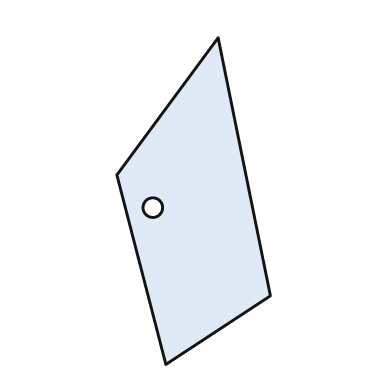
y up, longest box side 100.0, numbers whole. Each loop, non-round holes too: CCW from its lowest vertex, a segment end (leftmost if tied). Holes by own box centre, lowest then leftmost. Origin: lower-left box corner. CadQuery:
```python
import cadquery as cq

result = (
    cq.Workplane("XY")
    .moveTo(15.0, 0.0)
    .lineTo(47.0, 21.0)
    .lineTo(31.0, 100.0)
    .lineTo(0.0, 58.0)
    .close()
    .moveTo(11.0, 48.0)
    .circle(3.0)
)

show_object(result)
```